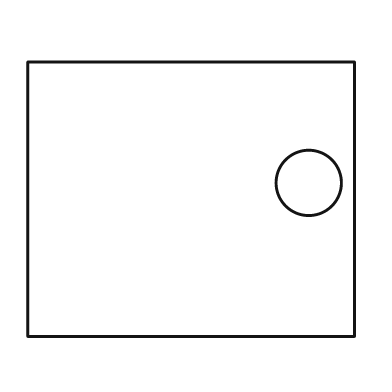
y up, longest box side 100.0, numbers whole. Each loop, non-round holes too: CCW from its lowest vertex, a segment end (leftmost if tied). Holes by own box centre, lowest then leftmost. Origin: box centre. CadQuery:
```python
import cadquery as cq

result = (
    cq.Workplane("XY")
    .moveTo(-50.0, -42.0)
    .lineTo(50.0, -42.0)
    .lineTo(50.0, 42.0)
    .lineTo(-50.0, 42.0)
    .close()
    .moveTo(36.0, 5.0)
    .circle(10.0)
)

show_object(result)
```